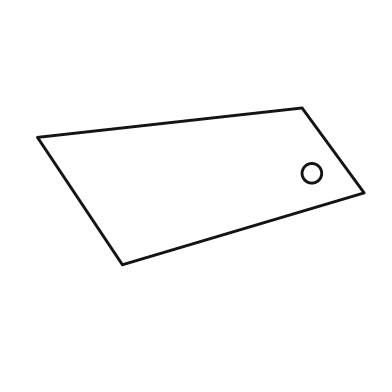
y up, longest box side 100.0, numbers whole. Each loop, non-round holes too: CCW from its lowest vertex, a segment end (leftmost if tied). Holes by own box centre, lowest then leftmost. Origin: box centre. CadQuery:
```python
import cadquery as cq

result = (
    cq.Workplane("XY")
    .moveTo(-24.0, -24.0)
    .lineTo(50.0, -2.0)
    .lineTo(31.0, 24.0)
    .lineTo(-50.0, 15.0)
    .close()
    .moveTo(34.0, 4.0)
    .circle(3.0)
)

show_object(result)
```